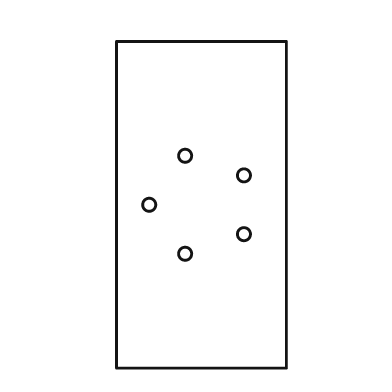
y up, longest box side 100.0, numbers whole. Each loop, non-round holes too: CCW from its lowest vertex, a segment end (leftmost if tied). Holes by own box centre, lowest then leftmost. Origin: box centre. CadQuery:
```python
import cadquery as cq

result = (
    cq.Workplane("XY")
    .moveTo(-26.0, -50.0)
    .lineTo(26.0, -50.0)
    .lineTo(26.0, 50.0)
    .lineTo(-26.0, 50.0)
    .close()
    .moveTo(-5.0, -15.0)
    .circle(2.0)
    .moveTo(13.0, -9.0)
    .circle(2.0)
    .moveTo(-16.0, 0.0)
    .circle(2.0)
    .moveTo(13.0, 9.0)
    .circle(2.0)
    .moveTo(-5.0, 15.0)
    .circle(2.0)
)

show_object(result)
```